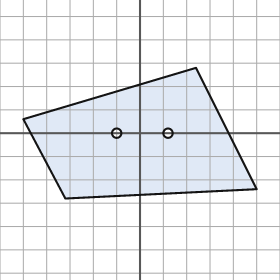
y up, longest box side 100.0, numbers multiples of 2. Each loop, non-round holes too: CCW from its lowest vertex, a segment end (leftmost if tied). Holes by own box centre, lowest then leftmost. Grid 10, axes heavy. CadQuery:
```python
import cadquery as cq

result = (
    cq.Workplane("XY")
    .moveTo(-32.0, -28.0)
    .lineTo(50.0, -24.0)
    .lineTo(24.0, 28.0)
    .lineTo(-50.0, 6.0)
    .close()
    .moveTo(-10.0, 0.0)
    .circle(2.0)
    .moveTo(12.0, 0.0)
    .circle(2.0)
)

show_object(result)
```